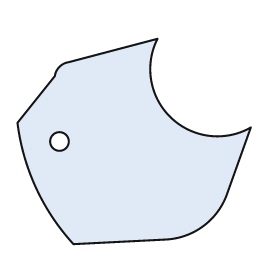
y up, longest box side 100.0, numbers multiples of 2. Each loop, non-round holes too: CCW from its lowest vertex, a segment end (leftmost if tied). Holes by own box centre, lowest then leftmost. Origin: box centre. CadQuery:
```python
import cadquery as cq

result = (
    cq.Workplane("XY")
    .moveTo(-26.0, -44.0)
    .lineTo(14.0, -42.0)
    .threePointArc((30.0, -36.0), (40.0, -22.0))
    .lineTo(50.0, 6.0)
    .threePointArc((16.0, 10.0), (10.0, 44.0))
    .lineTo(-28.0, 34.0)
    .threePointArc((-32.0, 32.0), (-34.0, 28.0))
    .lineTo(-50.0, 8.0)
    .threePointArc((-42.0, -20.0), (-26.0, -44.0))
    .close()
    .moveTo(-32.0, 0.0)
    .circle(4.0)
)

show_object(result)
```